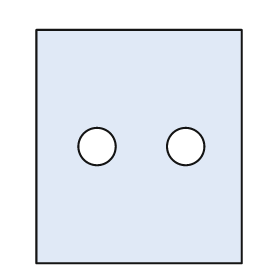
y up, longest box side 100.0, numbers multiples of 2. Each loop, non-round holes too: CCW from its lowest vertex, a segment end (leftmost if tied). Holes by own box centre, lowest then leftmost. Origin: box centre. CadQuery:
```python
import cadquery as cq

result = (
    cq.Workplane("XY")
    .moveTo(-44.0, -50.0)
    .lineTo(44.0, -50.0)
    .lineTo(44.0, 50.0)
    .lineTo(-44.0, 50.0)
    .close()
    .moveTo(-18.0, 0.0)
    .circle(8.0)
    .moveTo(20.0, 0.0)
    .circle(8.0)
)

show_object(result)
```